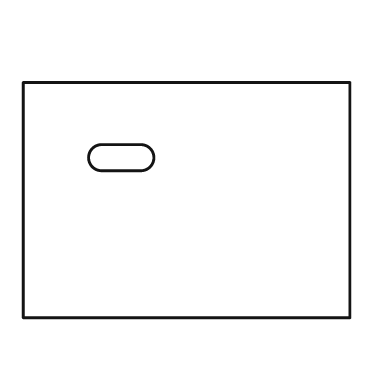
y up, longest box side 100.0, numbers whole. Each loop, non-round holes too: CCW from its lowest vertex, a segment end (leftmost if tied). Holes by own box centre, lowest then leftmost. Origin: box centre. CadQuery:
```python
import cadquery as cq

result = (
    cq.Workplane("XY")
    .moveTo(-50.0, -36.0)
    .lineTo(50.0, -36.0)
    .lineTo(50.0, 36.0)
    .lineTo(-50.0, 36.0)
    .close()
    .moveTo(-26.0, 9.0)
    .lineTo(-14.0, 9.0)
    .threePointArc((-10.0, 13.0), (-14.0, 17.0))
    .lineTo(-26.0, 17.0)
    .threePointArc((-30.0, 13.0), (-26.0, 9.0))
    .close()
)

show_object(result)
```